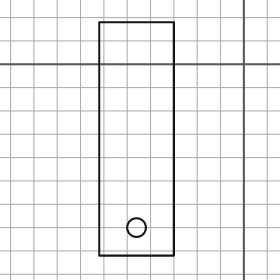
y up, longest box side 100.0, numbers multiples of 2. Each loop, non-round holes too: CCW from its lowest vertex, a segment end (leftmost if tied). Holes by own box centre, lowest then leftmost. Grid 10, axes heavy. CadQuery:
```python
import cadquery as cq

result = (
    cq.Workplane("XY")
    .moveTo(-62.0, -82.0)
    .lineTo(-30.0, -82.0)
    .lineTo(-30.0, 18.0)
    .lineTo(-62.0, 18.0)
    .close()
    .moveTo(-46.0, -70.0)
    .circle(4.0)
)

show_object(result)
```